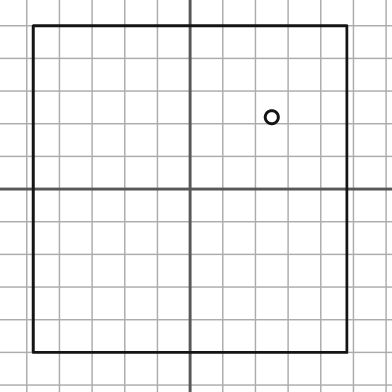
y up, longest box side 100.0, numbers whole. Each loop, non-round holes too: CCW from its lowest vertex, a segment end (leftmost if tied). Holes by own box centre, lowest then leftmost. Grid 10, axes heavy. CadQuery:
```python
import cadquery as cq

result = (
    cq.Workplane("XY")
    .moveTo(-48.0, -50.0)
    .lineTo(48.0, -50.0)
    .lineTo(48.0, 50.0)
    .lineTo(-48.0, 50.0)
    .close()
    .moveTo(25.0, 22.0)
    .circle(2.0)
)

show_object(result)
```